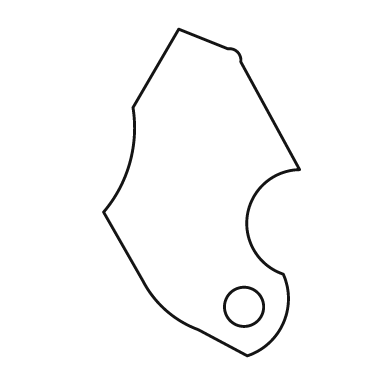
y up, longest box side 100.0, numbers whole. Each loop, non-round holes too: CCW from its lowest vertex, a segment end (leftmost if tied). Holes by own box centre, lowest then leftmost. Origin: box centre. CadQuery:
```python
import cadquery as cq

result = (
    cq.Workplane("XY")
    .moveTo(14.0, -50.0)
    .threePointArc((25.0, -40.0), (25.0, -25.0))
    .threePointArc((14.0, -7.0), (30.0, 7.0))
    .lineTo(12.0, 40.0)
    .threePointArc((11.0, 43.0), (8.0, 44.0))
    .lineTo(-7.0, 50.0)
    .lineTo(-21.0, 26.0)
    .threePointArc((-22.0, 9.0), (-30.0, -6.0))
    .lineTo(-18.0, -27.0)
    .threePointArc((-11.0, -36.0), (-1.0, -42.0))
    .close()
    .moveTo(13.0, -35.0)
    .circle(6.0)
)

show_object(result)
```